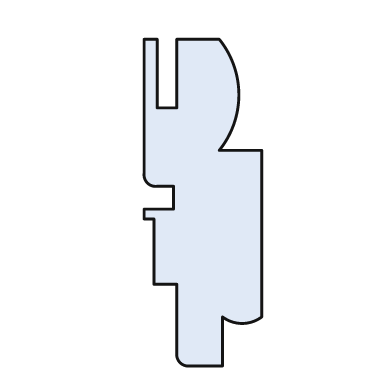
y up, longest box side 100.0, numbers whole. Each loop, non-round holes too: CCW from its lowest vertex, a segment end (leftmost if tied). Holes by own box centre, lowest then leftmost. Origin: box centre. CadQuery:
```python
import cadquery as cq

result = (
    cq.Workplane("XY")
    .moveTo(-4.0, -50.0)
    .lineTo(6.0, -50.0)
    .lineTo(6.0, -35.0)
    .threePointArc((12.0, -37.0), (18.0, -35.0))
    .lineTo(18.0, 16.0)
    .lineTo(5.0, 16.0)
    .threePointArc((11.0, 33.0), (5.0, 50.0))
    .lineTo(-8.0, 50.0)
    .lineTo(-8.0, 29.0)
    .lineTo(-14.0, 29.0)
    .lineTo(-14.0, 50.0)
    .lineTo(-18.0, 50.0)
    .lineTo(-18.0, 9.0)
    .threePointArc((-17.0, 6.0), (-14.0, 5.0))
    .lineTo(-9.0, 5.0)
    .lineTo(-9.0, -2.0)
    .lineTo(-18.0, -2.0)
    .lineTo(-18.0, -5.0)
    .lineTo(-15.0, -5.0)
    .lineTo(-15.0, -25.0)
    .lineTo(-8.0, -25.0)
    .lineTo(-8.0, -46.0)
    .threePointArc((-7.0, -49.0), (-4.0, -50.0))
    .close()
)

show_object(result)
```